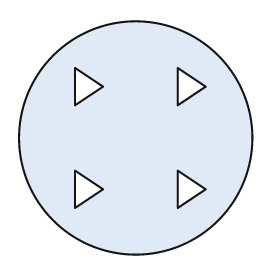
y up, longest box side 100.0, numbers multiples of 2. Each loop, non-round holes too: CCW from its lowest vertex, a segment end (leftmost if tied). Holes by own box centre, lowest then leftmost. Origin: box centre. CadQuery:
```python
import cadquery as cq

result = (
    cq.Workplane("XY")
    .moveTo(0.0, 0.0)
    .circle(50.0)
    .moveTo(-26.0, -30.0)
    .lineTo(-14.0, -22.0)
    .lineTo(-26.0, -14.0)
    .close()
    .moveTo(18.0, -30.0)
    .lineTo(30.0, -22.0)
    .lineTo(18.0, -14.0)
    .close()
    .moveTo(-26.0, 14.0)
    .lineTo(-14.0, 22.0)
    .lineTo(-26.0, 30.0)
    .close()
    .moveTo(18.0, 14.0)
    .lineTo(30.0, 22.0)
    .lineTo(18.0, 30.0)
    .close()
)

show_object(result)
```